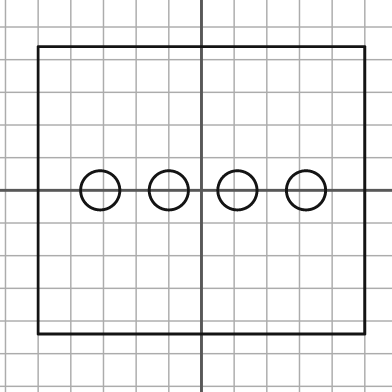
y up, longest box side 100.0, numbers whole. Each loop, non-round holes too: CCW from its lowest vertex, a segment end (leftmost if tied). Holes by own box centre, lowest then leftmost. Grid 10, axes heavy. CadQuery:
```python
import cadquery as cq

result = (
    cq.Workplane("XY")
    .moveTo(-50.0, -44.0)
    .lineTo(50.0, -44.0)
    .lineTo(50.0, 44.0)
    .lineTo(-50.0, 44.0)
    .close()
    .moveTo(-31.0, 0.0)
    .circle(6.0)
    .moveTo(-10.0, 0.0)
    .circle(6.0)
    .moveTo(11.0, 0.0)
    .circle(6.0)
    .moveTo(32.0, 0.0)
    .circle(6.0)
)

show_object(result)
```